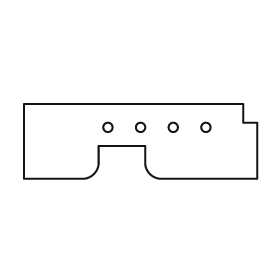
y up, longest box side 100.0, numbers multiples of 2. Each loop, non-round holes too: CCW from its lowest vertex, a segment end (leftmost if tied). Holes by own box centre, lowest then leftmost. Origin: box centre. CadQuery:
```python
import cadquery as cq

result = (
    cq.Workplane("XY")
    .moveTo(-50.0, -16.0)
    .lineTo(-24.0, -16.0)
    .threePointArc((-20.0, -14.0), (-18.0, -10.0))
    .lineTo(-18.0, -2.0)
    .lineTo(2.0, -2.0)
    .lineTo(2.0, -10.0)
    .threePointArc((4.0, -14.0), (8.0, -16.0))
    .lineTo(50.0, -16.0)
    .lineTo(50.0, 8.0)
    .lineTo(44.0, 8.0)
    .lineTo(44.0, 16.0)
    .lineTo(-50.0, 16.0)
    .close()
    .moveTo(-14.0, 6.0)
    .circle(2.0)
    .moveTo(0.0, 6.0)
    .circle(2.0)
    .moveTo(14.0, 6.0)
    .circle(2.0)
    .moveTo(28.0, 6.0)
    .circle(2.0)
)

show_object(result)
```